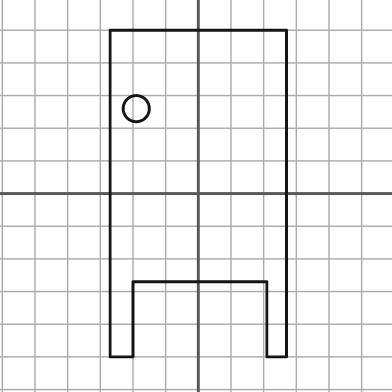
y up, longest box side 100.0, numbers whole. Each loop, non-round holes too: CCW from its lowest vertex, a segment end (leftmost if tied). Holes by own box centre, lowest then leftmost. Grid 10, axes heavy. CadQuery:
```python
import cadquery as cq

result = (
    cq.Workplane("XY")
    .moveTo(-27.0, -50.0)
    .lineTo(-20.0, -50.0)
    .lineTo(-20.0, -27.0)
    .lineTo(21.0, -27.0)
    .lineTo(21.0, -50.0)
    .lineTo(27.0, -50.0)
    .lineTo(27.0, 50.0)
    .lineTo(-27.0, 50.0)
    .close()
    .moveTo(-19.0, 26.0)
    .circle(4.0)
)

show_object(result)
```